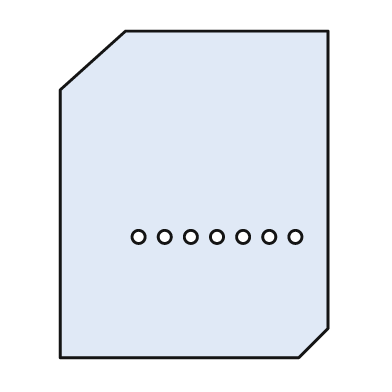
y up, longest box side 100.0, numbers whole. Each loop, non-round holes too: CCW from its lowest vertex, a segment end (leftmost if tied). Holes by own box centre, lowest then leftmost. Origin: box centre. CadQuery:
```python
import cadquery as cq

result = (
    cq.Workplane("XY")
    .moveTo(-41.0, -50.0)
    .lineTo(32.0, -50.0)
    .lineTo(41.0, -41.0)
    .lineTo(41.0, 50.0)
    .lineTo(-21.0, 50.0)
    .lineTo(-41.0, 32.0)
    .close()
    .moveTo(-17.0, -13.0)
    .circle(2.0)
    .moveTo(-9.0, -13.0)
    .circle(2.0)
    .moveTo(-1.0, -13.0)
    .circle(2.0)
    .moveTo(7.0, -13.0)
    .circle(2.0)
    .moveTo(15.0, -13.0)
    .circle(2.0)
    .moveTo(23.0, -13.0)
    .circle(2.0)
    .moveTo(31.0, -13.0)
    .circle(2.0)
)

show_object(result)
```